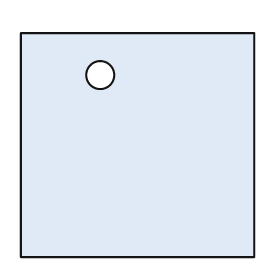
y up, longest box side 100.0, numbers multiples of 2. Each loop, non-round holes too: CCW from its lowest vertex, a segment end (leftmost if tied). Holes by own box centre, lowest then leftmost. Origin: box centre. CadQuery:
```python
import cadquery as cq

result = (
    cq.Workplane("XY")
    .moveTo(-50.0, -48.0)
    .lineTo(50.0, -48.0)
    .lineTo(50.0, 48.0)
    .lineTo(-50.0, 48.0)
    .close()
    .moveTo(-16.0, 30.0)
    .circle(6.0)
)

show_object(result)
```